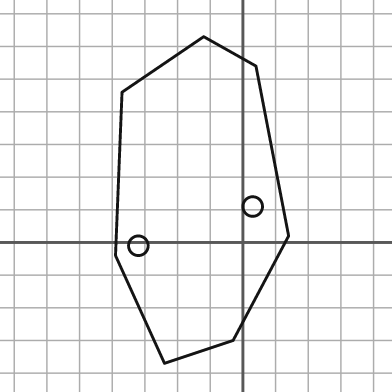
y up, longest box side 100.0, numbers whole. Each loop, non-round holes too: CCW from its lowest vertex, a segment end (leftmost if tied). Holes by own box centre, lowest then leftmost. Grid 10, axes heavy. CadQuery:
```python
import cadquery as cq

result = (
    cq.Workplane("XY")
    .moveTo(-24.0, -37.0)
    .lineTo(-3.0, -30.0)
    .lineTo(14.0, 2.0)
    .lineTo(4.0, 54.0)
    .lineTo(-12.0, 63.0)
    .lineTo(-37.0, 46.0)
    .lineTo(-39.0, -4.0)
    .close()
    .moveTo(-32.0, -1.0)
    .circle(3.0)
    .moveTo(3.0, 11.0)
    .circle(3.0)
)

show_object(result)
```